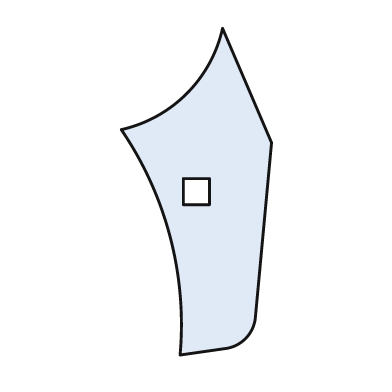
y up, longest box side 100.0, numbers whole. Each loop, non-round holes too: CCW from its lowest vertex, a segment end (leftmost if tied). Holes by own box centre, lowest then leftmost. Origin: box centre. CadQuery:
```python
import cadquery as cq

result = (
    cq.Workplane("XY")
    .moveTo(-5.0, -50.0)
    .lineTo(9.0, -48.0)
    .threePointArc((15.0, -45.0), (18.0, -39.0))
    .lineTo(23.0, 15.0)
    .lineTo(8.0, 50.0)
    .threePointArc((-3.0, 30.0), (-23.0, 19.0))
    .threePointArc((-8.0, -14.0), (-5.0, -50.0))
    .close()
    .moveTo(-4.0, -4.0)
    .lineTo(4.0, -4.0)
    .lineTo(4.0, 4.0)
    .lineTo(-4.0, 4.0)
    .close()
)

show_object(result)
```